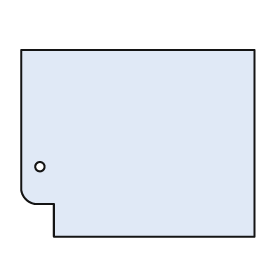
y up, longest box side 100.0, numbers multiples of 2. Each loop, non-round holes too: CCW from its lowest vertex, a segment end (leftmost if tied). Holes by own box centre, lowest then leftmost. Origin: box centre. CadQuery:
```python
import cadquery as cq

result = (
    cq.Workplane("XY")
    .moveTo(-36.0, -40.0)
    .lineTo(50.0, -40.0)
    .lineTo(50.0, 40.0)
    .lineTo(-50.0, 40.0)
    .lineTo(-50.0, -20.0)
    .threePointArc((-48.0, -24.0), (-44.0, -26.0))
    .lineTo(-36.0, -26.0)
    .close()
    .moveTo(-42.0, -10.0)
    .circle(2.0)
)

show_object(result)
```